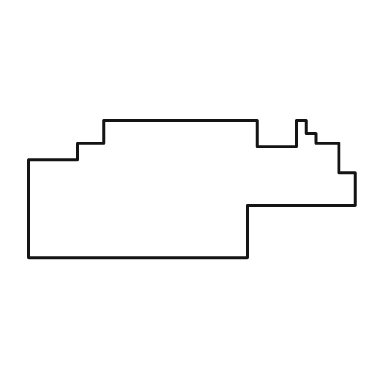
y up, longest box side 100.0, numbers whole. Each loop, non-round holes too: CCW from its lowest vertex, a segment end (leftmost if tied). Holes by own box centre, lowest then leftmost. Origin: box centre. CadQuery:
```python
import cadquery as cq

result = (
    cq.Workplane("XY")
    .moveTo(-50.0, -21.0)
    .lineTo(17.0, -21.0)
    .lineTo(17.0, -5.0)
    .lineTo(50.0, -5.0)
    .lineTo(50.0, 5.0)
    .lineTo(45.0, 5.0)
    .lineTo(45.0, 14.0)
    .lineTo(38.0, 14.0)
    .lineTo(38.0, 17.0)
    .lineTo(35.0, 17.0)
    .lineTo(35.0, 21.0)
    .lineTo(32.0, 21.0)
    .lineTo(32.0, 13.0)
    .lineTo(20.0, 13.0)
    .lineTo(20.0, 21.0)
    .lineTo(-27.0, 21.0)
    .lineTo(-27.0, 14.0)
    .lineTo(-35.0, 14.0)
    .lineTo(-35.0, 9.0)
    .lineTo(-50.0, 9.0)
    .close()
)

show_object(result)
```